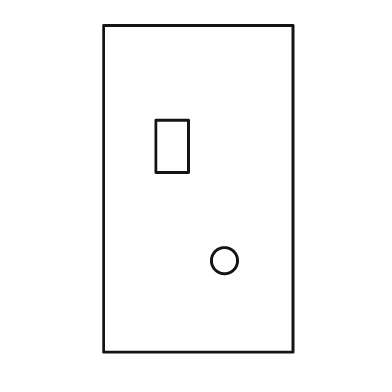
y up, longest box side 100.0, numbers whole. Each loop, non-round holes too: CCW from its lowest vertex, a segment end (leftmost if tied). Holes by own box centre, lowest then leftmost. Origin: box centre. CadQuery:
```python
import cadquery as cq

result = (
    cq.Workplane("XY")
    .moveTo(-29.0, -50.0)
    .lineTo(29.0, -50.0)
    .lineTo(29.0, 50.0)
    .lineTo(-29.0, 50.0)
    .close()
    .moveTo(8.0, -22.0)
    .circle(4.0)
    .moveTo(-13.0, 5.0)
    .lineTo(-3.0, 5.0)
    .lineTo(-3.0, 21.0)
    .lineTo(-13.0, 21.0)
    .close()
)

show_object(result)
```